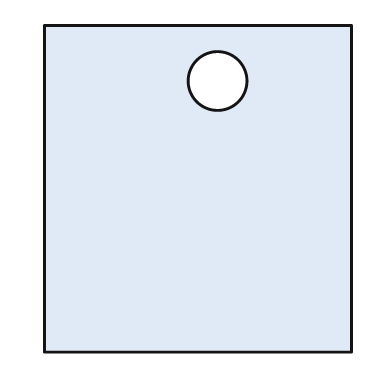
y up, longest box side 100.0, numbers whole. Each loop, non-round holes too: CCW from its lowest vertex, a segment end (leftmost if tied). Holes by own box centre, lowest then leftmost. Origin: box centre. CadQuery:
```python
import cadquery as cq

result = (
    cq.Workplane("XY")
    .moveTo(-47.0, -50.0)
    .lineTo(47.0, -50.0)
    .lineTo(47.0, 50.0)
    .lineTo(-47.0, 50.0)
    .close()
    .moveTo(6.0, 33.0)
    .circle(9.0)
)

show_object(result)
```